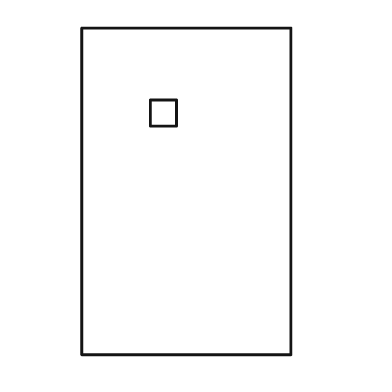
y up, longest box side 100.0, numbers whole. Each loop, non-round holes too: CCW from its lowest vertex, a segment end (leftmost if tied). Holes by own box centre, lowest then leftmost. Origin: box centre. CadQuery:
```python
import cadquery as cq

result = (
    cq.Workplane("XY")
    .moveTo(-32.0, -50.0)
    .lineTo(32.0, -50.0)
    .lineTo(32.0, 50.0)
    .lineTo(-32.0, 50.0)
    .close()
    .moveTo(-11.0, 20.0)
    .lineTo(-3.0, 20.0)
    .lineTo(-3.0, 28.0)
    .lineTo(-11.0, 28.0)
    .close()
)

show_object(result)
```